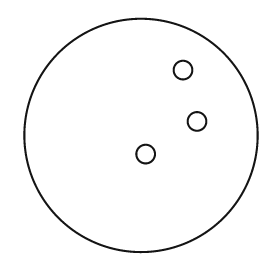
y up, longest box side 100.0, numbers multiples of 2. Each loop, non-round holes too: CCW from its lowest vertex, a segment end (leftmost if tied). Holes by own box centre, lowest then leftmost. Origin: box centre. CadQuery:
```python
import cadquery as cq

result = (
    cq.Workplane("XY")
    .moveTo(0.0, 0.0)
    .circle(50.0)
    .moveTo(2.0, -8.0)
    .circle(4.0)
    .moveTo(24.0, 6.0)
    .circle(4.0)
    .moveTo(18.0, 28.0)
    .circle(4.0)
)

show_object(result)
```